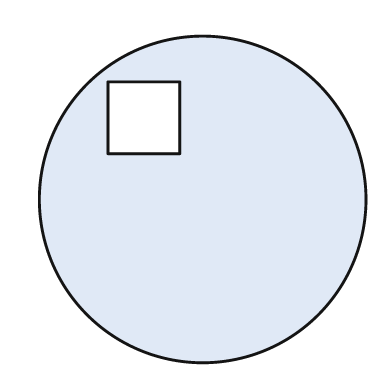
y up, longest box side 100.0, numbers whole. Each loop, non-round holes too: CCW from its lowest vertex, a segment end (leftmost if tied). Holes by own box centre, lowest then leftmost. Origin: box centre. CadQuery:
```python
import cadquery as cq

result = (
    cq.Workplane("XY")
    .moveTo(0.0, 0.0)
    .circle(50.0)
    .moveTo(-29.0, 14.0)
    .lineTo(-7.0, 14.0)
    .lineTo(-7.0, 36.0)
    .lineTo(-29.0, 36.0)
    .close()
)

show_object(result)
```